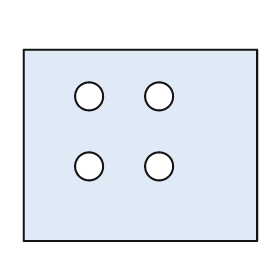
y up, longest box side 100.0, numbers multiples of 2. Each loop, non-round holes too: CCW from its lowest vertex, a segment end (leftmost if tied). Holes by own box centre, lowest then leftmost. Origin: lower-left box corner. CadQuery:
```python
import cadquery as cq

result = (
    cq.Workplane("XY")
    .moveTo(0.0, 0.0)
    .lineTo(100.0, 0.0)
    .lineTo(100.0, 82.0)
    .lineTo(0.0, 82.0)
    .close()
    .moveTo(28.0, 32.0)
    .circle(6.0)
    .moveTo(58.0, 32.0)
    .circle(6.0)
    .moveTo(28.0, 62.0)
    .circle(6.0)
    .moveTo(58.0, 62.0)
    .circle(6.0)
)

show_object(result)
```